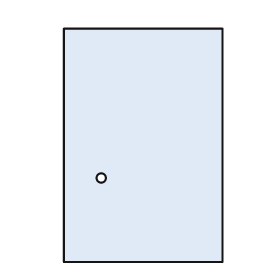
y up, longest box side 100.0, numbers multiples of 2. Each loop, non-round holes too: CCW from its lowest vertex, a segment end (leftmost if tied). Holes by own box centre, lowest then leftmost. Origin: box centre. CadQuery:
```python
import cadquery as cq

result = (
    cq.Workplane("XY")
    .moveTo(-34.0, -50.0)
    .lineTo(34.0, -50.0)
    .lineTo(34.0, 50.0)
    .lineTo(-34.0, 50.0)
    .close()
    .moveTo(-18.0, -14.0)
    .circle(2.0)
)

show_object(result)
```